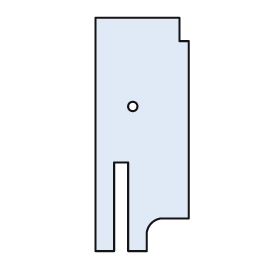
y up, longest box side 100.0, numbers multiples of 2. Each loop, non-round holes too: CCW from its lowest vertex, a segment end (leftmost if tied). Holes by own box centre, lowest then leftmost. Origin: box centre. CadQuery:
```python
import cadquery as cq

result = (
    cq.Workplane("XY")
    .moveTo(-20.0, -50.0)
    .lineTo(-12.0, -50.0)
    .lineTo(-12.0, -12.0)
    .lineTo(-6.0, -12.0)
    .lineTo(-6.0, -50.0)
    .lineTo(2.0, -50.0)
    .lineTo(2.0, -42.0)
    .threePointArc((4.0, -38.0), (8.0, -36.0))
    .lineTo(20.0, -36.0)
    .lineTo(20.0, 40.0)
    .lineTo(16.0, 40.0)
    .lineTo(16.0, 50.0)
    .lineTo(-20.0, 50.0)
    .close()
    .moveTo(-4.0, 12.0)
    .circle(2.0)
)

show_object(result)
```